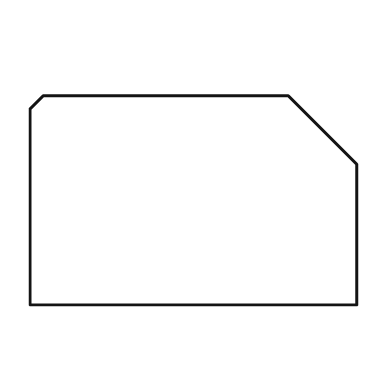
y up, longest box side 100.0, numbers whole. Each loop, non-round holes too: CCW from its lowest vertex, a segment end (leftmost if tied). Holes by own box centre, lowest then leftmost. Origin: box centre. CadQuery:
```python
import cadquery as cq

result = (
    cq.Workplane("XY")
    .moveTo(-50.0, -32.0)
    .lineTo(50.0, -32.0)
    .lineTo(50.0, 11.0)
    .lineTo(29.0, 32.0)
    .lineTo(-46.0, 32.0)
    .lineTo(-50.0, 28.0)
    .close()
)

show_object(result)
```